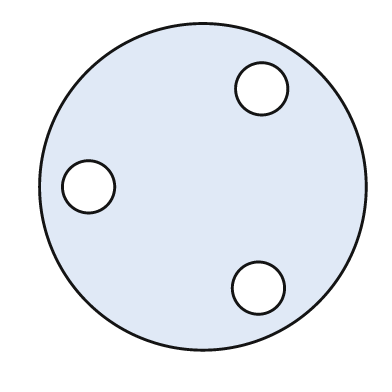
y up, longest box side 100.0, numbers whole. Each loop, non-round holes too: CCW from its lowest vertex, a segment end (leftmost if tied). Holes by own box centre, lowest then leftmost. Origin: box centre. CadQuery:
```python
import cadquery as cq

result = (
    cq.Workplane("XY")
    .moveTo(0.0, 0.0)
    .circle(50.0)
    .moveTo(17.0, -31.0)
    .circle(8.0)
    .moveTo(-35.0, 0.0)
    .circle(8.0)
    .moveTo(18.0, 30.0)
    .circle(8.0)
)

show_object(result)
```